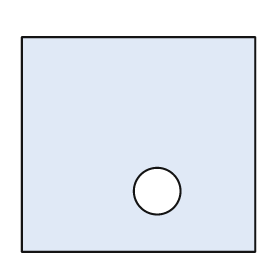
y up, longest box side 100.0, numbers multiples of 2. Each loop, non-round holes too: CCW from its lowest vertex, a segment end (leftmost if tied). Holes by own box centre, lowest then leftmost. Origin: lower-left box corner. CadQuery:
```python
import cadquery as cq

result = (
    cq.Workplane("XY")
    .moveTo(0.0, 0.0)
    .lineTo(100.0, 0.0)
    .lineTo(100.0, 92.0)
    .lineTo(0.0, 92.0)
    .close()
    .moveTo(58.0, 26.0)
    .circle(10.0)
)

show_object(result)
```